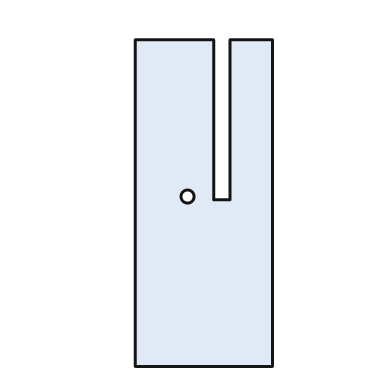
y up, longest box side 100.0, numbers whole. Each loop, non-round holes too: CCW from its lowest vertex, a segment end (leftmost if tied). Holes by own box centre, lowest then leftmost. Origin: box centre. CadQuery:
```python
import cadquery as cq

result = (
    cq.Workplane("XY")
    .moveTo(-21.0, -50.0)
    .lineTo(21.0, -50.0)
    .lineTo(21.0, 50.0)
    .lineTo(8.0, 50.0)
    .lineTo(8.0, 1.0)
    .lineTo(3.0, 1.0)
    .lineTo(3.0, 50.0)
    .lineTo(-21.0, 50.0)
    .close()
    .moveTo(-5.0, 2.0)
    .circle(2.0)
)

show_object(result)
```